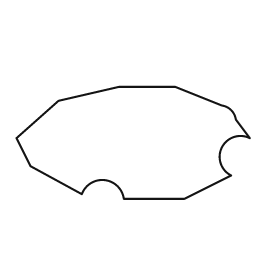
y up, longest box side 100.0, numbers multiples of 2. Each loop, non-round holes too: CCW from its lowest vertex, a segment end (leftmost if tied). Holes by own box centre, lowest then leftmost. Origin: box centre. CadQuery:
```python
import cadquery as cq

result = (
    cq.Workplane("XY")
    .moveTo(-4.0, -24.0)
    .lineTo(22.0, -24.0)
    .lineTo(42.0, -14.0)
    .threePointArc((38.0, -2.0), (50.0, 2.0))
    .lineTo(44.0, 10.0)
    .threePointArc((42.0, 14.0), (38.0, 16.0))
    .lineTo(18.0, 24.0)
    .lineTo(-6.0, 24.0)
    .lineTo(-32.0, 18.0)
    .lineTo(-50.0, 2.0)
    .lineTo(-44.0, -10.0)
    .lineTo(-22.0, -22.0)
    .threePointArc((-12.0, -16.0), (-4.0, -24.0))
    .close()
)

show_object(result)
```